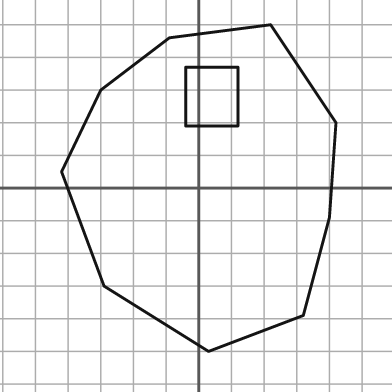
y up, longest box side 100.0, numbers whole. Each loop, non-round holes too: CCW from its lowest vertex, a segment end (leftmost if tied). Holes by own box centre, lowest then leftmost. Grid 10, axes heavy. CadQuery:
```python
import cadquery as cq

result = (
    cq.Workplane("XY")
    .moveTo(3.0, -50.0)
    .lineTo(32.0, -39.0)
    .lineTo(40.0, -9.0)
    .lineTo(42.0, 20.0)
    .lineTo(22.0, 50.0)
    .lineTo(-9.0, 46.0)
    .lineTo(-30.0, 30.0)
    .lineTo(-42.0, 5.0)
    .lineTo(-29.0, -30.0)
    .close()
    .moveTo(-4.0, 19.0)
    .lineTo(12.0, 19.0)
    .lineTo(12.0, 37.0)
    .lineTo(-4.0, 37.0)
    .close()
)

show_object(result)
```